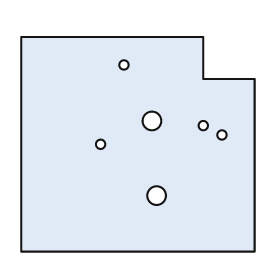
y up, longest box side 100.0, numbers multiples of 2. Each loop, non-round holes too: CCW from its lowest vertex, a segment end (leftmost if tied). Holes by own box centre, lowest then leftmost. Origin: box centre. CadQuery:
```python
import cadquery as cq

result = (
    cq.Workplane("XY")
    .moveTo(-50.0, -46.0)
    .lineTo(50.0, -46.0)
    .lineTo(50.0, 28.0)
    .lineTo(28.0, 28.0)
    .lineTo(28.0, 46.0)
    .lineTo(-50.0, 46.0)
    .close()
    .moveTo(8.0, -22.0)
    .circle(4.0)
    .moveTo(-16.0, 0.0)
    .circle(2.0)
    .moveTo(36.0, 4.0)
    .circle(2.0)
    .moveTo(28.0, 8.0)
    .circle(2.0)
    .moveTo(6.0, 10.0)
    .circle(4.0)
    .moveTo(-6.0, 34.0)
    .circle(2.0)
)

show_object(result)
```